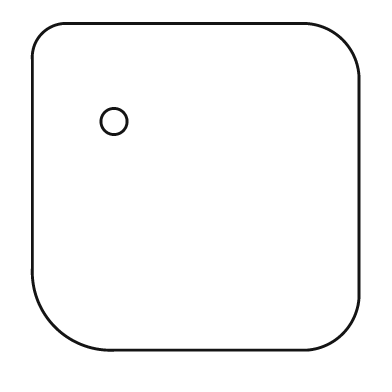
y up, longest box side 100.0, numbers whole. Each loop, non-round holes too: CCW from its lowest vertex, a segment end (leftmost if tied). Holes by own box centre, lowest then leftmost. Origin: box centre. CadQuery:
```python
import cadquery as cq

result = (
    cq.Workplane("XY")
    .moveTo(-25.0, -50.0)
    .lineTo(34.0, -50.0)
    .threePointArc((45.0, -45.0), (50.0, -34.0))
    .lineTo(50.0, 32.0)
    .threePointArc((45.0, 45.0), (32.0, 50.0))
    .lineTo(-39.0, 50.0)
    .threePointArc((-47.0, 47.0), (-50.0, 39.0))
    .lineTo(-50.0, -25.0)
    .threePointArc((-43.0, -43.0), (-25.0, -50.0))
    .close()
    .moveTo(-25.0, 20.0)
    .circle(4.0)
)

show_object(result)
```